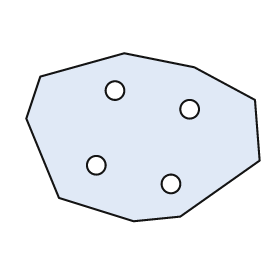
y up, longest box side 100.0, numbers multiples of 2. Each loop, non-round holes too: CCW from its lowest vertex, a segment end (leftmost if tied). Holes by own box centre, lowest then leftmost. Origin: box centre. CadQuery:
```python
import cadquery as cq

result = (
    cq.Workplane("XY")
    .moveTo(-4.0, -36.0)
    .lineTo(16.0, -34.0)
    .lineTo(50.0, -10.0)
    .lineTo(48.0, 16.0)
    .lineTo(22.0, 30.0)
    .lineTo(-8.0, 36.0)
    .lineTo(-44.0, 26.0)
    .lineTo(-50.0, 8.0)
    .lineTo(-36.0, -26.0)
    .close()
    .moveTo(12.0, -20.0)
    .circle(4.0)
    .moveTo(-20.0, -12.0)
    .circle(4.0)
    .moveTo(20.0, 12.0)
    .circle(4.0)
    .moveTo(-12.0, 20.0)
    .circle(4.0)
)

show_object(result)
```